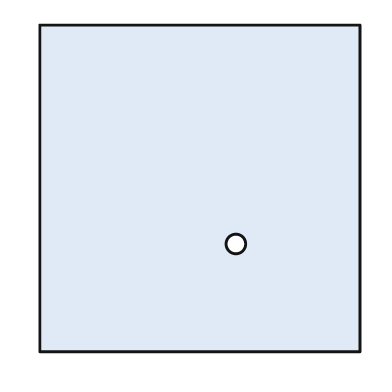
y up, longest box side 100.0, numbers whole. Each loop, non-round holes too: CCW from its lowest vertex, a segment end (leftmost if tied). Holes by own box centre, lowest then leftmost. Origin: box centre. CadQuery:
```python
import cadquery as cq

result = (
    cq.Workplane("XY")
    .moveTo(-49.0, -50.0)
    .lineTo(49.0, -50.0)
    .lineTo(49.0, 50.0)
    .lineTo(-49.0, 50.0)
    .close()
    .moveTo(11.0, -17.0)
    .circle(3.0)
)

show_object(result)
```